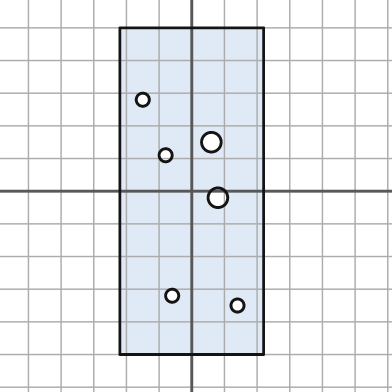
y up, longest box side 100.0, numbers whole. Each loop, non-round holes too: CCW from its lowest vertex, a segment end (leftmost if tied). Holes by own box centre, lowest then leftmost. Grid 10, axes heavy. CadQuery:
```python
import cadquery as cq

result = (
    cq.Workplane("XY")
    .moveTo(-22.0, -50.0)
    .lineTo(22.0, -50.0)
    .lineTo(22.0, 50.0)
    .lineTo(-22.0, 50.0)
    .close()
    .moveTo(14.0, -35.0)
    .circle(2.0)
    .moveTo(-6.0, -32.0)
    .circle(2.0)
    .moveTo(8.0, -2.0)
    .circle(3.0)
    .moveTo(-8.0, 11.0)
    .circle(2.0)
    .moveTo(6.0, 15.0)
    .circle(3.0)
    .moveTo(-15.0, 28.0)
    .circle(2.0)
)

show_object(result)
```